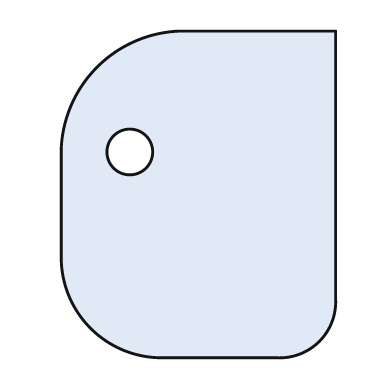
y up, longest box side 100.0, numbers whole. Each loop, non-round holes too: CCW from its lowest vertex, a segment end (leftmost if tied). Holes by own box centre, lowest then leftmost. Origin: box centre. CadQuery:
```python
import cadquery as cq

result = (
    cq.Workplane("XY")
    .moveTo(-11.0, -50.0)
    .lineTo(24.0, -50.0)
    .threePointArc((37.0, -45.0), (42.0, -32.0))
    .lineTo(42.0, 50.0)
    .lineTo(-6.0, 50.0)
    .threePointArc((-31.0, 39.0), (-42.0, 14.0))
    .lineTo(-42.0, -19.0)
    .threePointArc((-33.0, -41.0), (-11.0, -50.0))
    .close()
    .moveTo(-21.0, 13.0)
    .circle(7.0)
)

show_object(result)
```